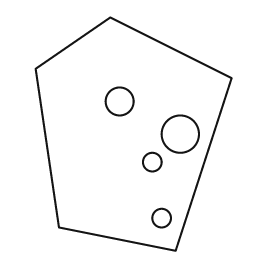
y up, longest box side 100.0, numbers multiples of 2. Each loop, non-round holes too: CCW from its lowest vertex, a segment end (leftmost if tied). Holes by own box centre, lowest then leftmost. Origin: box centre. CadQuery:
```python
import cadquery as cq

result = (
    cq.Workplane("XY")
    .moveTo(18.0, -50.0)
    .lineTo(42.0, 24.0)
    .lineTo(-10.0, 50.0)
    .lineTo(-42.0, 28.0)
    .lineTo(-32.0, -40.0)
    .close()
    .moveTo(12.0, -36.0)
    .circle(4.0)
    .moveTo(8.0, -12.0)
    .circle(4.0)
    .moveTo(20.0, 0.0)
    .circle(8.0)
    .moveTo(-6.0, 14.0)
    .circle(6.0)
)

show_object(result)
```